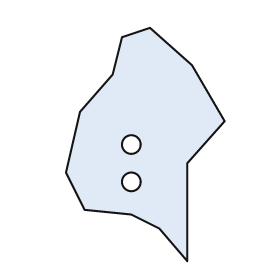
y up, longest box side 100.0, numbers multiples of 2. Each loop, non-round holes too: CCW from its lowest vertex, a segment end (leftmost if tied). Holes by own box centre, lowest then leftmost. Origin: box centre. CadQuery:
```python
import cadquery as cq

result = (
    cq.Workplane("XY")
    .moveTo(18.0, -50.0)
    .lineTo(18.0, -8.0)
    .lineTo(34.0, 10.0)
    .lineTo(20.0, 34.0)
    .lineTo(2.0, 50.0)
    .lineTo(-10.0, 46.0)
    .lineTo(-14.0, 30.0)
    .lineTo(-28.0, 14.0)
    .lineTo(-34.0, -12.0)
    .lineTo(-26.0, -28.0)
    .lineTo(-6.0, -30.0)
    .lineTo(6.0, -36.0)
    .close()
    .moveTo(-6.0, -16.0)
    .circle(4.0)
    .moveTo(-6.0, 0.0)
    .circle(4.0)
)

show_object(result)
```